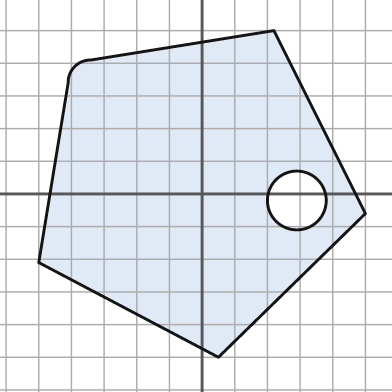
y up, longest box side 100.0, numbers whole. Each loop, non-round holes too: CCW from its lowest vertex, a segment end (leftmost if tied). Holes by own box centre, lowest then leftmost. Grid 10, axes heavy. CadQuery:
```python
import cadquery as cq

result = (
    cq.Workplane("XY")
    .moveTo(5.0, -50.0)
    .lineTo(50.0, -6.0)
    .lineTo(22.0, 50.0)
    .lineTo(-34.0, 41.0)
    .threePointArc((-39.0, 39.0), (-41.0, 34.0))
    .lineTo(-50.0, -21.0)
    .close()
    .moveTo(29.0, -2.0)
    .circle(9.0)
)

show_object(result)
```